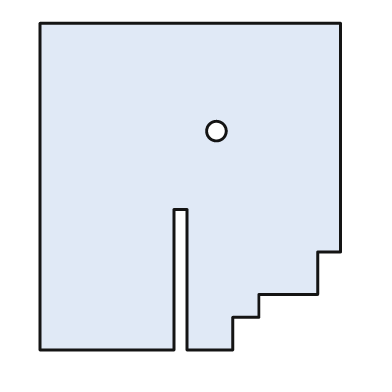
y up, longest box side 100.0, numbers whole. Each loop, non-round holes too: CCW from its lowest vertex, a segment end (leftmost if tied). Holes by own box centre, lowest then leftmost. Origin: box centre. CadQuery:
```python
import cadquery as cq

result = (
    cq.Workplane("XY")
    .moveTo(-46.0, -50.0)
    .lineTo(-5.0, -50.0)
    .lineTo(-5.0, -7.0)
    .lineTo(-1.0, -7.0)
    .lineTo(-1.0, -50.0)
    .lineTo(13.0, -50.0)
    .lineTo(13.0, -40.0)
    .lineTo(21.0, -40.0)
    .lineTo(21.0, -33.0)
    .lineTo(39.0, -33.0)
    .lineTo(39.0, -20.0)
    .lineTo(46.0, -20.0)
    .lineTo(46.0, 50.0)
    .lineTo(-46.0, 50.0)
    .close()
    .moveTo(8.0, 17.0)
    .circle(3.0)
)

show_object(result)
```